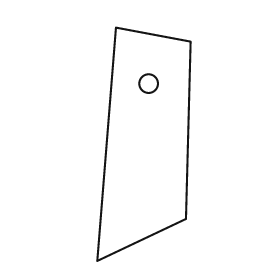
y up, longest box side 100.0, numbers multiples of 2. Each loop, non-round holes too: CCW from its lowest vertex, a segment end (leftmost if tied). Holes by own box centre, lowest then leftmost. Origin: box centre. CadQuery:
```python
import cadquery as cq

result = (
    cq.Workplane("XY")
    .moveTo(-20.0, -50.0)
    .lineTo(18.0, -32.0)
    .lineTo(20.0, 44.0)
    .lineTo(-12.0, 50.0)
    .close()
    .moveTo(2.0, 26.0)
    .circle(4.0)
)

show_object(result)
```